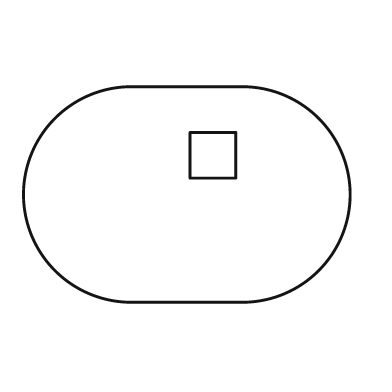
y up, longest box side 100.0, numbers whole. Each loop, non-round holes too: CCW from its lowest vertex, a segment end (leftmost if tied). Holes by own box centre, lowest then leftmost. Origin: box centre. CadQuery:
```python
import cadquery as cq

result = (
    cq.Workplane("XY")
    .moveTo(-17.0, -33.0)
    .lineTo(17.0, -33.0)
    .threePointArc((50.0, 0.0), (17.0, 33.0))
    .lineTo(-17.0, 33.0)
    .threePointArc((-50.0, 0.0), (-17.0, -33.0))
    .close()
    .moveTo(1.0, 5.0)
    .lineTo(15.0, 5.0)
    .lineTo(15.0, 19.0)
    .lineTo(1.0, 19.0)
    .close()
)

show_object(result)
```